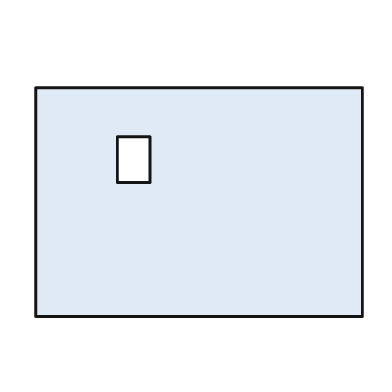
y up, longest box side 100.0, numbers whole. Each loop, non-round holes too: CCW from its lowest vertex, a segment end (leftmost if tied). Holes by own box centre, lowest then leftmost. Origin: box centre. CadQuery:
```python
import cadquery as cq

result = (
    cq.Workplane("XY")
    .moveTo(-50.0, -35.0)
    .lineTo(50.0, -35.0)
    .lineTo(50.0, 35.0)
    .lineTo(-50.0, 35.0)
    .close()
    .moveTo(-25.0, 6.0)
    .lineTo(-15.0, 6.0)
    .lineTo(-15.0, 20.0)
    .lineTo(-25.0, 20.0)
    .close()
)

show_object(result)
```